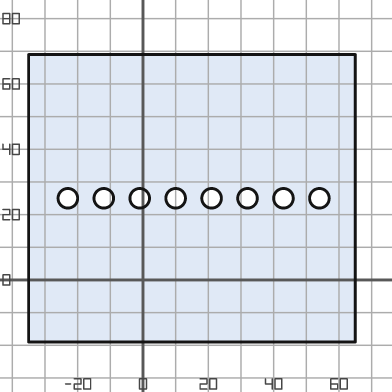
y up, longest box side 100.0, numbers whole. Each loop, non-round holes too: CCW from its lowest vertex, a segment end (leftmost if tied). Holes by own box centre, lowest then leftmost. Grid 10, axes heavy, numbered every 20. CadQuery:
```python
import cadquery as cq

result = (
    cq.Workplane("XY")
    .moveTo(-35.0, -19.0)
    .lineTo(65.0, -19.0)
    .lineTo(65.0, 69.0)
    .lineTo(-35.0, 69.0)
    .close()
    .moveTo(-23.0, 25.0)
    .circle(3.0)
    .moveTo(-12.0, 25.0)
    .circle(3.0)
    .moveTo(-1.0, 25.0)
    .circle(3.0)
    .moveTo(10.0, 25.0)
    .circle(3.0)
    .moveTo(21.0, 25.0)
    .circle(3.0)
    .moveTo(32.0, 25.0)
    .circle(3.0)
    .moveTo(43.0, 25.0)
    .circle(3.0)
    .moveTo(54.0, 25.0)
    .circle(3.0)
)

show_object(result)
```